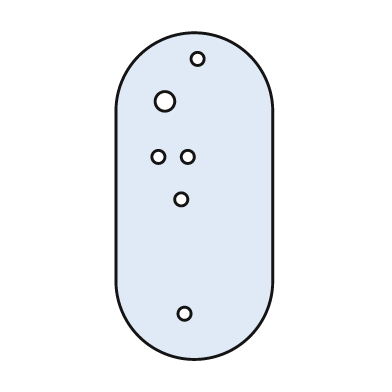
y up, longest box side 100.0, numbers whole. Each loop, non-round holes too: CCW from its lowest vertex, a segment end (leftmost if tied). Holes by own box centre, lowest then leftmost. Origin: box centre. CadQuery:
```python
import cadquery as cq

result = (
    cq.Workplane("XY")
    .moveTo(-24.0, -26.0)
    .threePointArc((0.0, -50.0), (24.0, -26.0))
    .lineTo(24.0, 26.0)
    .threePointArc((0.0, 50.0), (-24.0, 26.0))
    .close()
    .moveTo(-3.0, -36.0)
    .circle(2.0)
    .moveTo(-4.0, -1.0)
    .circle(2.0)
    .moveTo(-11.0, 12.0)
    .circle(2.0)
    .moveTo(-2.0, 12.0)
    .circle(2.0)
    .moveTo(-9.0, 29.0)
    .circle(3.0)
    .moveTo(1.0, 42.0)
    .circle(2.0)
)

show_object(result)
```